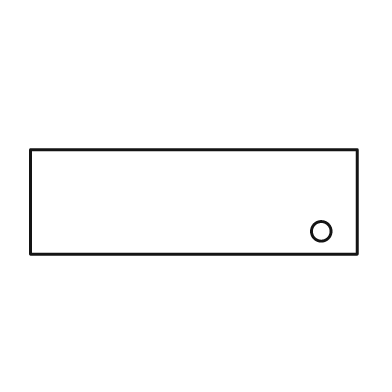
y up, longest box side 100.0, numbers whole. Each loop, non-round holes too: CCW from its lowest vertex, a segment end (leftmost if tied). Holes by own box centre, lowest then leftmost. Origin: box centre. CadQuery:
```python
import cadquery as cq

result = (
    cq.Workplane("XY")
    .moveTo(-50.0, -16.0)
    .lineTo(50.0, -16.0)
    .lineTo(50.0, 16.0)
    .lineTo(-50.0, 16.0)
    .close()
    .moveTo(39.0, -9.0)
    .circle(3.0)
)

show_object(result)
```